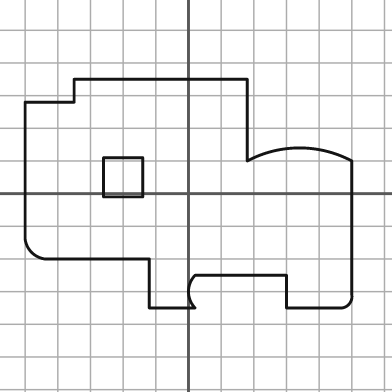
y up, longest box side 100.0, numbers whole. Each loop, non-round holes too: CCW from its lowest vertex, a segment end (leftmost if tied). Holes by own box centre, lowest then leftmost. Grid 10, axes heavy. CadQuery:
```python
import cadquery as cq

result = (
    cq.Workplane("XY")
    .moveTo(-12.0, -35.0)
    .lineTo(2.0, -35.0)
    .threePointArc((0.0, -30.0), (2.0, -25.0))
    .lineTo(30.0, -25.0)
    .lineTo(30.0, -35.0)
    .lineTo(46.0, -35.0)
    .threePointArc((49.0, -34.0), (50.0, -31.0))
    .lineTo(50.0, 10.0)
    .threePointArc((34.0, 14.0), (18.0, 10.0))
    .lineTo(18.0, 35.0)
    .lineTo(-35.0, 35.0)
    .lineTo(-35.0, 28.0)
    .lineTo(-50.0, 28.0)
    .lineTo(-50.0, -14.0)
    .threePointArc((-48.0, -18.0), (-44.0, -20.0))
    .lineTo(-12.0, -20.0)
    .close()
    .moveTo(-26.0, -1.0)
    .lineTo(-14.0, -1.0)
    .lineTo(-14.0, 11.0)
    .lineTo(-26.0, 11.0)
    .close()
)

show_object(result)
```